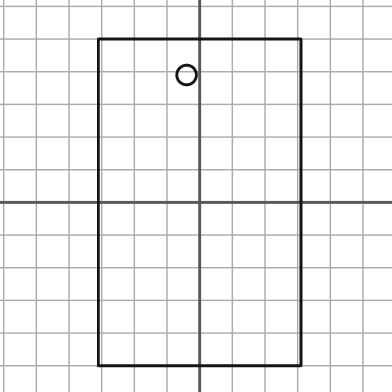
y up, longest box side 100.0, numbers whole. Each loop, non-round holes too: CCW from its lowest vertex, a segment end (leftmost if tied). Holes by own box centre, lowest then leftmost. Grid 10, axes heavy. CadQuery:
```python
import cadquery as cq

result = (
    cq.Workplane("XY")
    .moveTo(-31.0, -50.0)
    .lineTo(31.0, -50.0)
    .lineTo(31.0, 50.0)
    .lineTo(-31.0, 50.0)
    .close()
    .moveTo(-4.0, 39.0)
    .circle(3.0)
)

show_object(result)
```